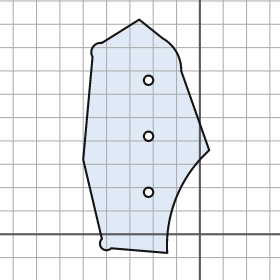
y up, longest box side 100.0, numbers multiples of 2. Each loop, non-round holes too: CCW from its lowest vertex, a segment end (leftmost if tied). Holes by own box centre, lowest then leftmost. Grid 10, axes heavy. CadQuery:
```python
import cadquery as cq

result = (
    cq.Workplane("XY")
    .moveTo(-14.0, -8.0)
    .threePointArc((-10.0, 16.0), (4.0, 36.0))
    .lineTo(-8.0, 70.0)
    .threePointArc((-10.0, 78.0), (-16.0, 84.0))
    .lineTo(-26.0, 92.0)
    .lineTo(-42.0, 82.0)
    .threePointArc((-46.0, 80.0), (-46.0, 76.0))
    .lineTo(-50.0, 32.0)
    .lineTo(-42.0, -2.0)
    .threePointArc((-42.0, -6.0), (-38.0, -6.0))
    .close()
    .moveTo(-22.0, 18.0)
    .circle(2.0)
    .moveTo(-22.0, 42.0)
    .circle(2.0)
    .moveTo(-22.0, 66.0)
    .circle(2.0)
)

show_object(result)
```